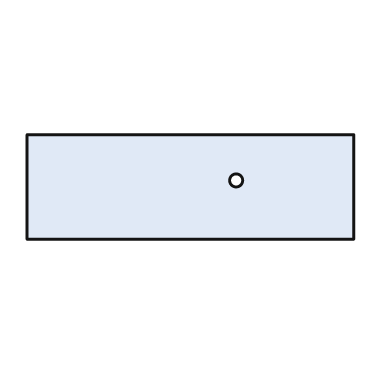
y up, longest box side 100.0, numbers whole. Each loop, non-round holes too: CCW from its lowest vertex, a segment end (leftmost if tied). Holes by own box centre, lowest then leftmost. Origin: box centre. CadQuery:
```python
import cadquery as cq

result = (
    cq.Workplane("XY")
    .moveTo(-50.0, -16.0)
    .lineTo(50.0, -16.0)
    .lineTo(50.0, 16.0)
    .lineTo(-50.0, 16.0)
    .close()
    .moveTo(14.0, 2.0)
    .circle(2.0)
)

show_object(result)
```